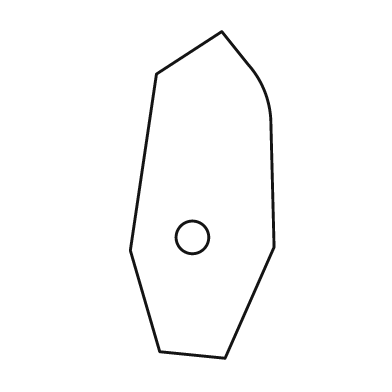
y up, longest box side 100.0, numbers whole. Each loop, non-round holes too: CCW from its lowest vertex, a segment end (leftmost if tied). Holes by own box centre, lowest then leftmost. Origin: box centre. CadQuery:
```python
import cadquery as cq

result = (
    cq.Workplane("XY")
    .moveTo(7.0, -50.0)
    .lineTo(22.0, -16.0)
    .lineTo(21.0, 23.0)
    .threePointArc((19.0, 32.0), (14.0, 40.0))
    .lineTo(6.0, 50.0)
    .lineTo(-14.0, 37.0)
    .lineTo(-22.0, -17.0)
    .lineTo(-13.0, -48.0)
    .close()
    .moveTo(-3.0, -13.0)
    .circle(5.0)
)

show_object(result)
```